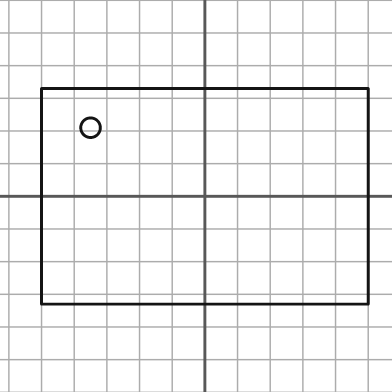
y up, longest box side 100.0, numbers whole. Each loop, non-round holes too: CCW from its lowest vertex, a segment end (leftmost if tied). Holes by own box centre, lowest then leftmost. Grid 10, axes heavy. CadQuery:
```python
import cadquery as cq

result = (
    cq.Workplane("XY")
    .moveTo(-50.0, -33.0)
    .lineTo(50.0, -33.0)
    .lineTo(50.0, 33.0)
    .lineTo(-50.0, 33.0)
    .close()
    .moveTo(-35.0, 21.0)
    .circle(3.0)
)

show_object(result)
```